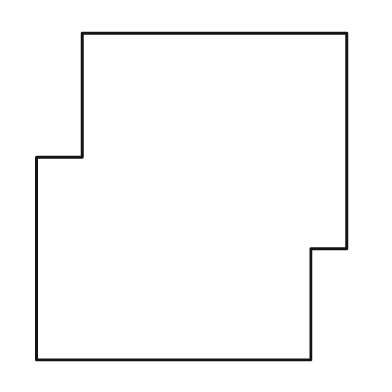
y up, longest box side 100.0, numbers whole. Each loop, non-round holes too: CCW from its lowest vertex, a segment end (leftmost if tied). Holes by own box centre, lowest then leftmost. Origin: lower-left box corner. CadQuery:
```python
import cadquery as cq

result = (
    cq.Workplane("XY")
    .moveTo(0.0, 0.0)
    .lineTo(84.0, 0.0)
    .lineTo(84.0, 34.0)
    .lineTo(95.0, 34.0)
    .lineTo(95.0, 100.0)
    .lineTo(14.0, 100.0)
    .lineTo(14.0, 62.0)
    .lineTo(0.0, 62.0)
    .close()
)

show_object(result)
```